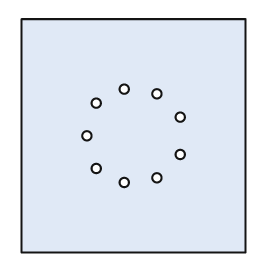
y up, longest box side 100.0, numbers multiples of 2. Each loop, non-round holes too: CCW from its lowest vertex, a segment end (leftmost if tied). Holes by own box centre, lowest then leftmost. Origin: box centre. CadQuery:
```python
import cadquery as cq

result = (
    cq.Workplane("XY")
    .moveTo(-48.0, -50.0)
    .lineTo(48.0, -50.0)
    .lineTo(48.0, 50.0)
    .lineTo(-48.0, 50.0)
    .close()
    .moveTo(-4.0, -20.0)
    .circle(2.0)
    .moveTo(10.0, -18.0)
    .circle(2.0)
    .moveTo(-16.0, -14.0)
    .circle(2.0)
    .moveTo(20.0, -8.0)
    .circle(2.0)
    .moveTo(-20.0, 0.0)
    .circle(2.0)
    .moveTo(20.0, 8.0)
    .circle(2.0)
    .moveTo(-16.0, 14.0)
    .circle(2.0)
    .moveTo(10.0, 18.0)
    .circle(2.0)
    .moveTo(-4.0, 20.0)
    .circle(2.0)
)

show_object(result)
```